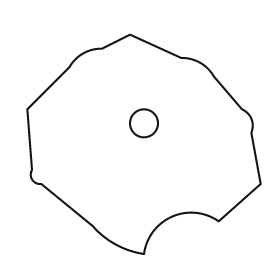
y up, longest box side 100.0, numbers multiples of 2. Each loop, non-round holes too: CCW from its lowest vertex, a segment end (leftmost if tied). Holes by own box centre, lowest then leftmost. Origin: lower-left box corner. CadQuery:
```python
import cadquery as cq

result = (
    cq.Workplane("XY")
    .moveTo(50.0, 0.0)
    .threePointArc((62.0, 16.0), (82.0, 14.0))
    .lineTo(100.0, 30.0)
    .lineTo(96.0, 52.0)
    .threePointArc((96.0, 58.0), (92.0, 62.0))
    .lineTo(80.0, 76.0)
    .threePointArc((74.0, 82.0), (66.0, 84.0))
    .lineTo(44.0, 94.0)
    .lineTo(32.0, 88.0)
    .threePointArc((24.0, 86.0), (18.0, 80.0))
    .lineTo(0.0, 62.0)
    .lineTo(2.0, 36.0)
    .threePointArc((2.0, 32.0), (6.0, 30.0))
    .lineTo(28.0, 12.0)
    .threePointArc((38.0, 4.0), (50.0, 0.0))
    .close()
    .moveTo(50.0, 56.0)
    .circle(6.0)
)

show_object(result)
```